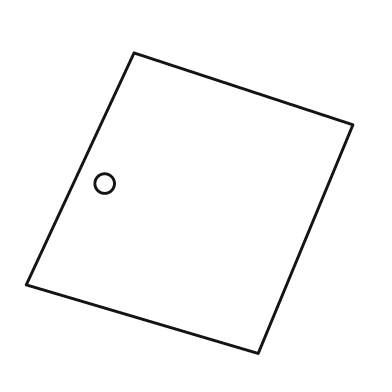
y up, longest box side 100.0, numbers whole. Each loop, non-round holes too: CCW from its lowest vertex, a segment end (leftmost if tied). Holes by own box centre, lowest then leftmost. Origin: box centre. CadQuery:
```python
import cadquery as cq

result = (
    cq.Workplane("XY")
    .moveTo(21.0, -46.0)
    .lineTo(50.0, 24.0)
    .lineTo(-17.0, 46.0)
    .lineTo(-50.0, -25.0)
    .close()
    .moveTo(-26.0, 6.0)
    .circle(3.0)
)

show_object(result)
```